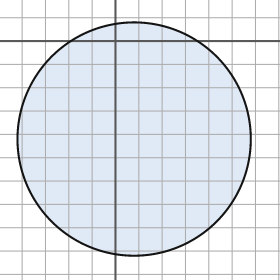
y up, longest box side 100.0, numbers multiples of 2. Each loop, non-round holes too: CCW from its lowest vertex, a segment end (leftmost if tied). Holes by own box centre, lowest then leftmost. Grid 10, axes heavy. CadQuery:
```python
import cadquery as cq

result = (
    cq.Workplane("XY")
    .moveTo(8.0, -42.0)
    .circle(50.0)
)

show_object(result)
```